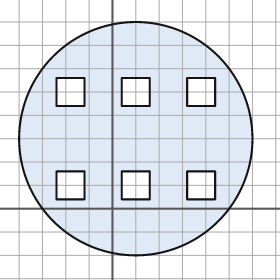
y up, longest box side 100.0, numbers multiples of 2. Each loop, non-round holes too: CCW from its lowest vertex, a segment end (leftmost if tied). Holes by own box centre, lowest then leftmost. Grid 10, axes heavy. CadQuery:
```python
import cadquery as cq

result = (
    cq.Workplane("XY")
    .moveTo(10.0, 30.0)
    .circle(50.0)
    .moveTo(-24.0, 4.0)
    .lineTo(-12.0, 4.0)
    .lineTo(-12.0, 16.0)
    .lineTo(-24.0, 16.0)
    .close()
    .moveTo(4.0, 4.0)
    .lineTo(16.0, 4.0)
    .lineTo(16.0, 16.0)
    .lineTo(4.0, 16.0)
    .close()
    .moveTo(32.0, 4.0)
    .lineTo(44.0, 4.0)
    .lineTo(44.0, 16.0)
    .lineTo(32.0, 16.0)
    .close()
    .moveTo(-24.0, 44.0)
    .lineTo(-12.0, 44.0)
    .lineTo(-12.0, 56.0)
    .lineTo(-24.0, 56.0)
    .close()
    .moveTo(4.0, 44.0)
    .lineTo(16.0, 44.0)
    .lineTo(16.0, 56.0)
    .lineTo(4.0, 56.0)
    .close()
    .moveTo(32.0, 44.0)
    .lineTo(44.0, 44.0)
    .lineTo(44.0, 56.0)
    .lineTo(32.0, 56.0)
    .close()
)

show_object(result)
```